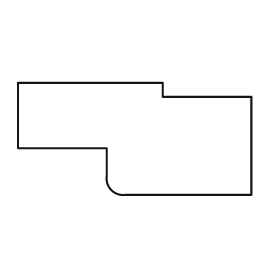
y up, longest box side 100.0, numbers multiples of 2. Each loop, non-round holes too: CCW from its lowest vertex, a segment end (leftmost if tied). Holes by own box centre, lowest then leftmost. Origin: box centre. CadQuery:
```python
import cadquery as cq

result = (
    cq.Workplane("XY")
    .moveTo(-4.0, -24.0)
    .lineTo(50.0, -24.0)
    .lineTo(50.0, 18.0)
    .lineTo(12.0, 18.0)
    .lineTo(12.0, 24.0)
    .lineTo(-50.0, 24.0)
    .lineTo(-50.0, -4.0)
    .lineTo(-12.0, -4.0)
    .lineTo(-12.0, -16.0)
    .threePointArc((-10.0, -22.0), (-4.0, -24.0))
    .close()
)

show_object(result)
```